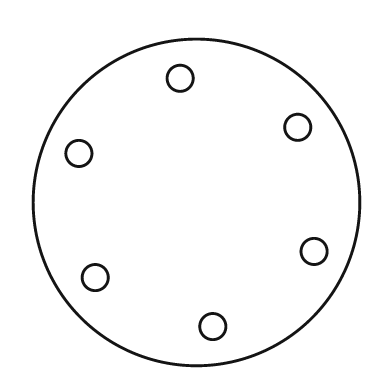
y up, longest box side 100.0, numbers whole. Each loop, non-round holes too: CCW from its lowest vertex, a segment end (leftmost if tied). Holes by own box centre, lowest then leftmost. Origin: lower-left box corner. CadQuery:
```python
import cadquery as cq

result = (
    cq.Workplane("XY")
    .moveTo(50.0, 50.0)
    .circle(50.0)
    .moveTo(55.0, 12.0)
    .circle(4.0)
    .moveTo(19.0, 27.0)
    .circle(4.0)
    .moveTo(86.0, 35.0)
    .circle(4.0)
    .moveTo(14.0, 65.0)
    .circle(4.0)
    .moveTo(81.0, 73.0)
    .circle(4.0)
    .moveTo(45.0, 88.0)
    .circle(4.0)
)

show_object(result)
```